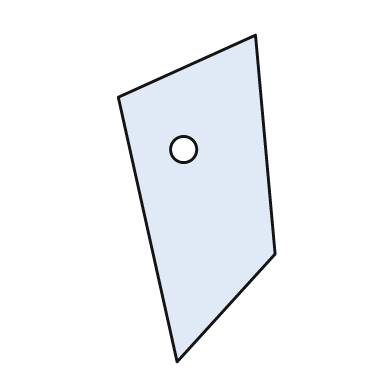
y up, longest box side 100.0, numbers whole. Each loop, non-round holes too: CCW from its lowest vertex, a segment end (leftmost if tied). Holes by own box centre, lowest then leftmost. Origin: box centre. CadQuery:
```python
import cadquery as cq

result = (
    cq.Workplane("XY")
    .moveTo(-6.0, -50.0)
    .lineTo(24.0, -17.0)
    .lineTo(18.0, 50.0)
    .lineTo(-24.0, 31.0)
    .close()
    .moveTo(-4.0, 15.0)
    .circle(4.0)
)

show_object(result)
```